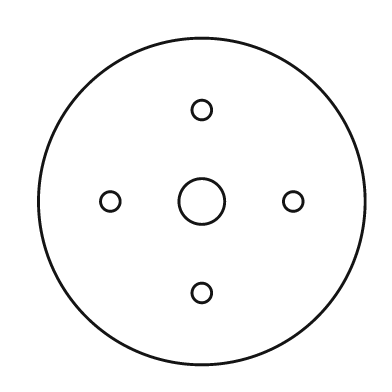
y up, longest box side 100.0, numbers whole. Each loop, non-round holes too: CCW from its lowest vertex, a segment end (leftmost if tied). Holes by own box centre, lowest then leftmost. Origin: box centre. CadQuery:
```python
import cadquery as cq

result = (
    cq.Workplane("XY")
    .moveTo(0.0, 0.0)
    .circle(50.0)
    .moveTo(0.0, -28.0)
    .circle(3.0)
    .moveTo(-28.0, 0.0)
    .circle(3.0)
    .moveTo(0.0, 0.0)
    .circle(7.0)
    .moveTo(28.0, 0.0)
    .circle(3.0)
    .moveTo(0.0, 28.0)
    .circle(3.0)
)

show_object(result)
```